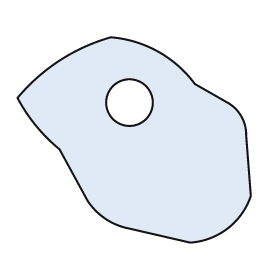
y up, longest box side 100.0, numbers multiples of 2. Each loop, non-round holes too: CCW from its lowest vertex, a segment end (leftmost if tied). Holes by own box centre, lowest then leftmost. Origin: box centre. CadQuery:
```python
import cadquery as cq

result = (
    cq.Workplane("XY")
    .moveTo(24.0, -44.0)
    .threePointArc((40.0, -38.0), (50.0, -24.0))
    .lineTo(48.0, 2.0)
    .threePointArc((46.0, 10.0), (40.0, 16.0))
    .lineTo(26.0, 24.0)
    .threePointArc((10.0, 38.0), (-10.0, 44.0))
    .threePointArc((-32.0, 34.0), (-50.0, 18.0))
    .threePointArc((-42.0, 6.0), (-32.0, -4.0))
    .lineTo(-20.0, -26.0)
    .threePointArc((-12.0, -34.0), (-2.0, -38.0))
    .close()
    .moveTo(-2.0, 16.0)
    .circle(10.0)
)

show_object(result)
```